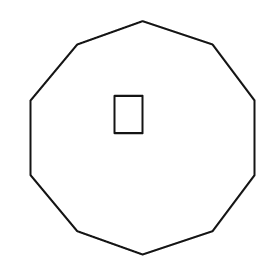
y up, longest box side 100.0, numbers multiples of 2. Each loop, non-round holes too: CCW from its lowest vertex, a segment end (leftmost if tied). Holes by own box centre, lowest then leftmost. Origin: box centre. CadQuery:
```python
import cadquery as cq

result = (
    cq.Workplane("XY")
    .moveTo(0.0, -50.0)
    .lineTo(30.0, -40.0)
    .lineTo(48.0, -16.0)
    .lineTo(48.0, 16.0)
    .lineTo(30.0, 40.0)
    .lineTo(0.0, 50.0)
    .lineTo(-28.0, 40.0)
    .lineTo(-48.0, 16.0)
    .lineTo(-48.0, -16.0)
    .lineTo(-28.0, -40.0)
    .close()
    .moveTo(-12.0, 2.0)
    .lineTo(0.0, 2.0)
    .lineTo(0.0, 18.0)
    .lineTo(-12.0, 18.0)
    .close()
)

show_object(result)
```